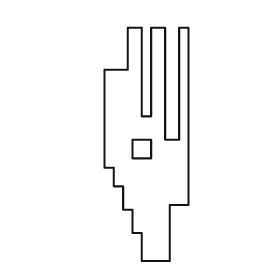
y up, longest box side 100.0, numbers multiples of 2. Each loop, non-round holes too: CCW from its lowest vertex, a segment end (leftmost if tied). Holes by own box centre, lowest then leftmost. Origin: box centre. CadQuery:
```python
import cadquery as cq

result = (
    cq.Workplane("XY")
    .moveTo(-2.0, -50.0)
    .lineTo(10.0, -50.0)
    .lineTo(10.0, -26.0)
    .lineTo(18.0, -26.0)
    .lineTo(18.0, 50.0)
    .lineTo(14.0, 50.0)
    .lineTo(14.0, 2.0)
    .lineTo(8.0, 2.0)
    .lineTo(8.0, 50.0)
    .lineTo(2.0, 50.0)
    .lineTo(2.0, 12.0)
    .lineTo(-2.0, 12.0)
    .lineTo(-2.0, 50.0)
    .lineTo(-8.0, 50.0)
    .lineTo(-8.0, 32.0)
    .lineTo(-18.0, 32.0)
    .lineTo(-18.0, -10.0)
    .lineTo(-14.0, -10.0)
    .lineTo(-14.0, -18.0)
    .lineTo(-10.0, -18.0)
    .lineTo(-10.0, -28.0)
    .lineTo(-6.0, -28.0)
    .lineTo(-6.0, -38.0)
    .lineTo(-2.0, -38.0)
    .close()
    .moveTo(-6.0, -6.0)
    .lineTo(2.0, -6.0)
    .lineTo(2.0, 2.0)
    .lineTo(-6.0, 2.0)
    .close()
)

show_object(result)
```